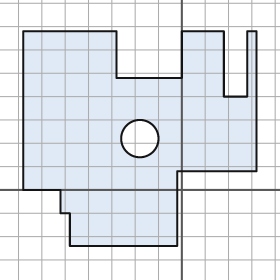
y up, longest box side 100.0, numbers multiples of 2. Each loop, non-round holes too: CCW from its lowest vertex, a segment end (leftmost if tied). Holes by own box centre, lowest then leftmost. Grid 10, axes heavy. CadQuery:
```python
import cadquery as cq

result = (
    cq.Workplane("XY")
    .moveTo(-48.0, -24.0)
    .lineTo(-2.0, -24.0)
    .lineTo(-2.0, 8.0)
    .lineTo(32.0, 8.0)
    .lineTo(32.0, 68.0)
    .lineTo(28.0, 68.0)
    .lineTo(28.0, 40.0)
    .lineTo(18.0, 40.0)
    .lineTo(18.0, 68.0)
    .lineTo(0.0, 68.0)
    .lineTo(0.0, 48.0)
    .lineTo(-28.0, 48.0)
    .lineTo(-28.0, 68.0)
    .lineTo(-68.0, 68.0)
    .lineTo(-68.0, 0.0)
    .lineTo(-52.0, 0.0)
    .lineTo(-52.0, -10.0)
    .lineTo(-48.0, -10.0)
    .close()
    .moveTo(-18.0, 22.0)
    .circle(8.0)
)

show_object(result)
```